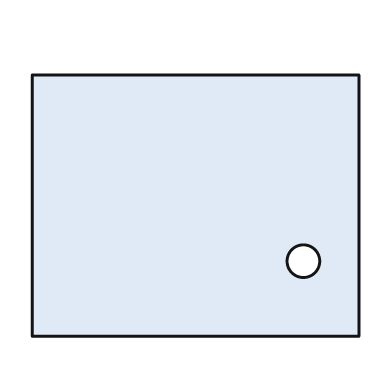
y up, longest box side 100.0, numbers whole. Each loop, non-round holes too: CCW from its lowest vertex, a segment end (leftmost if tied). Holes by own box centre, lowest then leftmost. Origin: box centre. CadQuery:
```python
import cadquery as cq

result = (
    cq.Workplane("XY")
    .moveTo(-50.0, -40.0)
    .lineTo(50.0, -40.0)
    .lineTo(50.0, 40.0)
    .lineTo(-50.0, 40.0)
    .close()
    .moveTo(33.0, -17.0)
    .circle(5.0)
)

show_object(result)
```